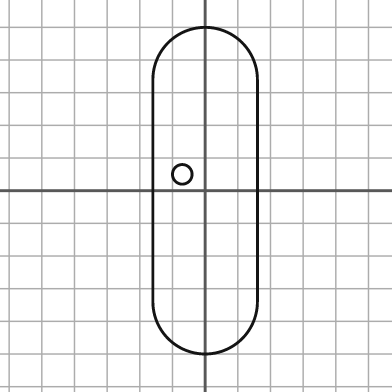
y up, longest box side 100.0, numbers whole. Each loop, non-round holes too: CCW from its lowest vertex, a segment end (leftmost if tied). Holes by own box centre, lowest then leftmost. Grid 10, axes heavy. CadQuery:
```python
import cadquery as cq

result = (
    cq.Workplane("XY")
    .moveTo(-16.0, -34.0)
    .threePointArc((0.0, -50.0), (16.0, -34.0))
    .lineTo(16.0, 34.0)
    .threePointArc((0.0, 50.0), (-16.0, 34.0))
    .close()
    .moveTo(-7.0, 5.0)
    .circle(3.0)
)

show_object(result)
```